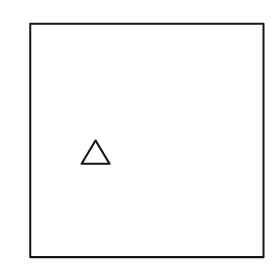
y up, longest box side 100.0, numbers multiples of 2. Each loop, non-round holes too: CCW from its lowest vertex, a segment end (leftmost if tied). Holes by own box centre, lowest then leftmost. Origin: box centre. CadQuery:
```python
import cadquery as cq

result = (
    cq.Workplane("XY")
    .moveTo(-50.0, -50.0)
    .lineTo(50.0, -50.0)
    .lineTo(50.0, 50.0)
    .lineTo(-50.0, 50.0)
    .close()
    .moveTo(-28.0, -10.0)
    .lineTo(-16.0, -10.0)
    .lineTo(-22.0, 0.0)
    .close()
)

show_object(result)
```